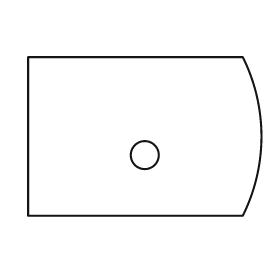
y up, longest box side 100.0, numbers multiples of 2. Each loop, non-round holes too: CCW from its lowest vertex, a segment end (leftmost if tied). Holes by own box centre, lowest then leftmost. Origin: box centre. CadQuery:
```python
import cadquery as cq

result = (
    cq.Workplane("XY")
    .moveTo(-50.0, -34.0)
    .lineTo(42.0, -34.0)
    .threePointArc((50.0, 0.0), (42.0, 34.0))
    .lineTo(-50.0, 34.0)
    .close()
    .moveTo(0.0, -8.0)
    .circle(6.0)
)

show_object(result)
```